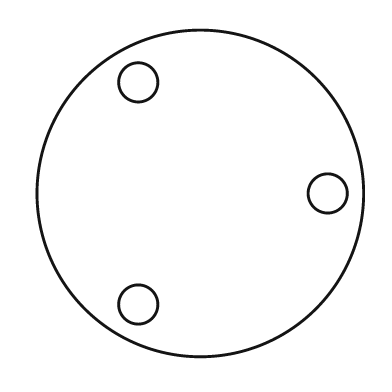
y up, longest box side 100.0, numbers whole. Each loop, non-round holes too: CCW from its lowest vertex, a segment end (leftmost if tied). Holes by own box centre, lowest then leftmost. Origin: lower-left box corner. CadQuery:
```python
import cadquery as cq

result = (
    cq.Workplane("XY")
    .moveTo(50.0, 50.0)
    .circle(50.0)
    .moveTo(31.0, 16.0)
    .circle(6.0)
    .moveTo(89.0, 50.0)
    .circle(6.0)
    .moveTo(31.0, 84.0)
    .circle(6.0)
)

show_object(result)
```